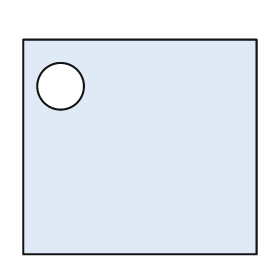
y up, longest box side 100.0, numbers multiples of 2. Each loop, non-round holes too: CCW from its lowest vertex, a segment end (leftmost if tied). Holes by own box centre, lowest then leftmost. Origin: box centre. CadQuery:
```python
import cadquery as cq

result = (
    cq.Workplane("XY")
    .moveTo(-50.0, -46.0)
    .lineTo(50.0, -46.0)
    .lineTo(50.0, 46.0)
    .lineTo(-50.0, 46.0)
    .close()
    .moveTo(-34.0, 26.0)
    .circle(10.0)
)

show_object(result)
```